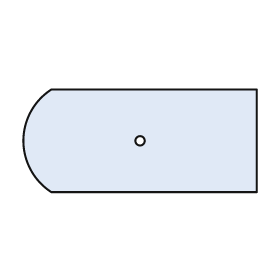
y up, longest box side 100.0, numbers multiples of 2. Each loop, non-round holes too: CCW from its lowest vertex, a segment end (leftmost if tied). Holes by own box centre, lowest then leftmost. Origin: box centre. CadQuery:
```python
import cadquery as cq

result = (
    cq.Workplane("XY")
    .moveTo(-38.0, -22.0)
    .lineTo(50.0, -22.0)
    .lineTo(50.0, 22.0)
    .lineTo(-38.0, 22.0)
    .threePointArc((-50.0, 0.0), (-38.0, -22.0))
    .close()
    .moveTo(0.0, 0.0)
    .circle(2.0)
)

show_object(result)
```